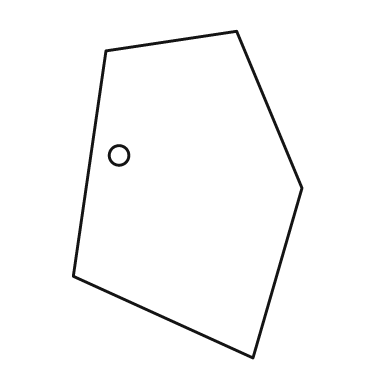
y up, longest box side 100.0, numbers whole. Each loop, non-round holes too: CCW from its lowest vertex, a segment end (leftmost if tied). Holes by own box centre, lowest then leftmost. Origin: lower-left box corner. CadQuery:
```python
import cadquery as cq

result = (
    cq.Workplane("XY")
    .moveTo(55.0, 0.0)
    .lineTo(70.0, 52.0)
    .lineTo(50.0, 100.0)
    .lineTo(10.0, 94.0)
    .lineTo(0.0, 25.0)
    .close()
    .moveTo(14.0, 62.0)
    .circle(3.0)
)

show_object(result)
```